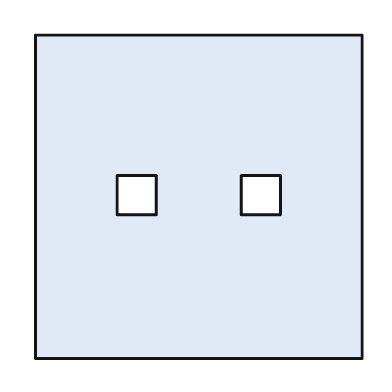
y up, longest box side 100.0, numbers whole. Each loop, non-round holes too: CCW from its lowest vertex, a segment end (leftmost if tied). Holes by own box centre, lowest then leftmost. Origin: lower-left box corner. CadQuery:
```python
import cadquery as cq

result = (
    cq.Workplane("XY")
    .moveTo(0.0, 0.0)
    .lineTo(100.0, 0.0)
    .lineTo(100.0, 99.0)
    .lineTo(0.0, 99.0)
    .close()
    .moveTo(25.0, 44.0)
    .lineTo(37.0, 44.0)
    .lineTo(37.0, 56.0)
    .lineTo(25.0, 56.0)
    .close()
    .moveTo(63.0, 44.0)
    .lineTo(75.0, 44.0)
    .lineTo(75.0, 56.0)
    .lineTo(63.0, 56.0)
    .close()
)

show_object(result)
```